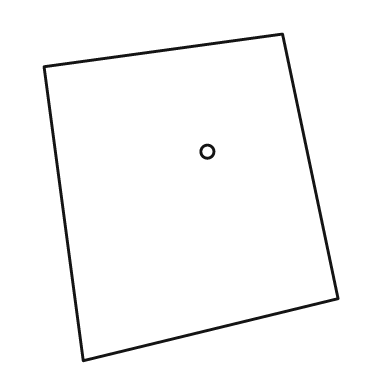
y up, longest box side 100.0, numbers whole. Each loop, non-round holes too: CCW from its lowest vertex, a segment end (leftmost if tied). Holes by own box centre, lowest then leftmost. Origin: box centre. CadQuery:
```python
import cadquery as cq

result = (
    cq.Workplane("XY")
    .moveTo(-33.0, -50.0)
    .lineTo(45.0, -31.0)
    .lineTo(28.0, 50.0)
    .lineTo(-45.0, 40.0)
    .close()
    .moveTo(5.0, 14.0)
    .circle(2.0)
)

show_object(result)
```